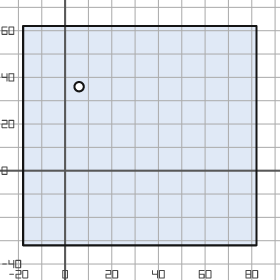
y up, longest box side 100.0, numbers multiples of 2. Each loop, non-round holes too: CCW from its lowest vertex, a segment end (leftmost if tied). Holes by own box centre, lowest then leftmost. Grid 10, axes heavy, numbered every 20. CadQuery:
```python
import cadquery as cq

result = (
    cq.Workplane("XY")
    .moveTo(-18.0, -32.0)
    .lineTo(82.0, -32.0)
    .lineTo(82.0, 62.0)
    .lineTo(-18.0, 62.0)
    .close()
    .moveTo(6.0, 36.0)
    .circle(2.0)
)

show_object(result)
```